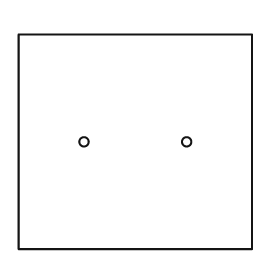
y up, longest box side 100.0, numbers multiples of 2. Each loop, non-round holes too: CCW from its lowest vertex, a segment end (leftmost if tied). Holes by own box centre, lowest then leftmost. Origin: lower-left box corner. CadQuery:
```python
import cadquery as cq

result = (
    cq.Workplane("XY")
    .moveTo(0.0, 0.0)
    .lineTo(100.0, 0.0)
    .lineTo(100.0, 92.0)
    .lineTo(0.0, 92.0)
    .close()
    .moveTo(28.0, 46.0)
    .circle(2.0)
    .moveTo(72.0, 46.0)
    .circle(2.0)
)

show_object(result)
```